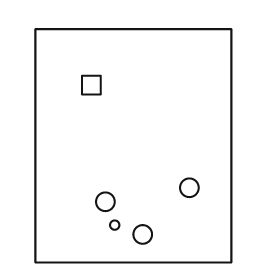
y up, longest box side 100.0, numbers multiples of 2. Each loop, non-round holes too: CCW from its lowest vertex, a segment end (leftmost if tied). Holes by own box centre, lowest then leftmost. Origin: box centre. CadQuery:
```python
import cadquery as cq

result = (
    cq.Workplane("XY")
    .moveTo(-42.0, -50.0)
    .lineTo(42.0, -50.0)
    .lineTo(42.0, 50.0)
    .lineTo(-42.0, 50.0)
    .close()
    .moveTo(4.0, -38.0)
    .circle(4.0)
    .moveTo(-8.0, -34.0)
    .circle(2.0)
    .moveTo(-12.0, -24.0)
    .circle(4.0)
    .moveTo(24.0, -18.0)
    .circle(4.0)
    .moveTo(-22.0, 22.0)
    .lineTo(-14.0, 22.0)
    .lineTo(-14.0, 30.0)
    .lineTo(-22.0, 30.0)
    .close()
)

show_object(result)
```